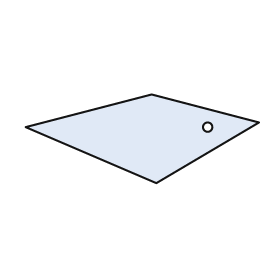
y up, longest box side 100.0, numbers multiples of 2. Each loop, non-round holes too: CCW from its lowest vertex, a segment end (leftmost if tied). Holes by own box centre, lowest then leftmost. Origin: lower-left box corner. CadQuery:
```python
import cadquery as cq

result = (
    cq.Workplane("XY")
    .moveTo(56.0, 0.0)
    .lineTo(100.0, 26.0)
    .lineTo(54.0, 38.0)
    .lineTo(0.0, 24.0)
    .close()
    .moveTo(78.0, 24.0)
    .circle(2.0)
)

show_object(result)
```